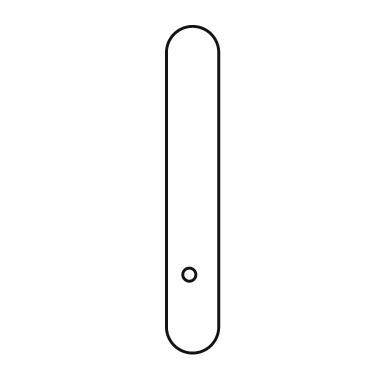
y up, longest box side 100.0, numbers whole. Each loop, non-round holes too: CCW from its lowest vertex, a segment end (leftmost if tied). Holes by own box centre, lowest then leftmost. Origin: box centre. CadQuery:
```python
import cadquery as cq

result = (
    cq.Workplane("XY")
    .moveTo(-8.0, -42.0)
    .threePointArc((0.0, -50.0), (8.0, -42.0))
    .lineTo(8.0, 42.0)
    .threePointArc((0.0, 50.0), (-8.0, 42.0))
    .close()
    .moveTo(-1.0, -26.0)
    .circle(2.0)
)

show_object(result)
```